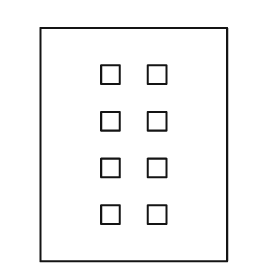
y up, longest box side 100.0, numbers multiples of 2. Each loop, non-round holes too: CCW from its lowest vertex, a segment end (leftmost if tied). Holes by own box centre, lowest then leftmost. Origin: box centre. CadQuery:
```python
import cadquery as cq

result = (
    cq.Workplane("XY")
    .moveTo(-40.0, -50.0)
    .lineTo(40.0, -50.0)
    .lineTo(40.0, 50.0)
    .lineTo(-40.0, 50.0)
    .close()
    .moveTo(-14.0, -34.0)
    .lineTo(-6.0, -34.0)
    .lineTo(-6.0, -26.0)
    .lineTo(-14.0, -26.0)
    .close()
    .moveTo(6.0, -34.0)
    .lineTo(14.0, -34.0)
    .lineTo(14.0, -26.0)
    .lineTo(6.0, -26.0)
    .close()
    .moveTo(-14.0, -14.0)
    .lineTo(-6.0, -14.0)
    .lineTo(-6.0, -6.0)
    .lineTo(-14.0, -6.0)
    .close()
    .moveTo(6.0, -14.0)
    .lineTo(14.0, -14.0)
    .lineTo(14.0, -6.0)
    .lineTo(6.0, -6.0)
    .close()
    .moveTo(-14.0, 6.0)
    .lineTo(-6.0, 6.0)
    .lineTo(-6.0, 14.0)
    .lineTo(-14.0, 14.0)
    .close()
    .moveTo(6.0, 6.0)
    .lineTo(14.0, 6.0)
    .lineTo(14.0, 14.0)
    .lineTo(6.0, 14.0)
    .close()
    .moveTo(-14.0, 26.0)
    .lineTo(-6.0, 26.0)
    .lineTo(-6.0, 34.0)
    .lineTo(-14.0, 34.0)
    .close()
    .moveTo(6.0, 26.0)
    .lineTo(14.0, 26.0)
    .lineTo(14.0, 34.0)
    .lineTo(6.0, 34.0)
    .close()
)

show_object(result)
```